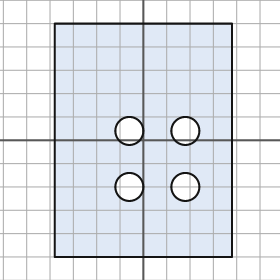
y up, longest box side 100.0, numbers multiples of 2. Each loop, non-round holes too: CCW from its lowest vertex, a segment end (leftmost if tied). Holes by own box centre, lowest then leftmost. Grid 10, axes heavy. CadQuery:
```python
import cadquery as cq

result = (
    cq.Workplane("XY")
    .moveTo(-38.0, -50.0)
    .lineTo(38.0, -50.0)
    .lineTo(38.0, 50.0)
    .lineTo(-38.0, 50.0)
    .close()
    .moveTo(-6.0, -20.0)
    .circle(6.0)
    .moveTo(18.0, -20.0)
    .circle(6.0)
    .moveTo(-6.0, 4.0)
    .circle(6.0)
    .moveTo(18.0, 4.0)
    .circle(6.0)
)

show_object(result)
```